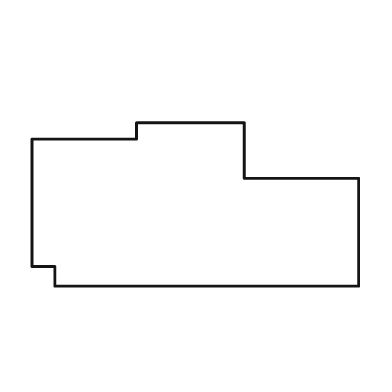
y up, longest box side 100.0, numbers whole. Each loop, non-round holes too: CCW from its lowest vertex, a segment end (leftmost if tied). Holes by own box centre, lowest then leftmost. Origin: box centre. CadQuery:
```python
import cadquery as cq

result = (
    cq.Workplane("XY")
    .moveTo(-43.0, -25.0)
    .lineTo(50.0, -25.0)
    .lineTo(50.0, 8.0)
    .lineTo(15.0, 8.0)
    .lineTo(15.0, 25.0)
    .lineTo(-18.0, 25.0)
    .lineTo(-18.0, 20.0)
    .lineTo(-50.0, 20.0)
    .lineTo(-50.0, -19.0)
    .lineTo(-43.0, -19.0)
    .close()
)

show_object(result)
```